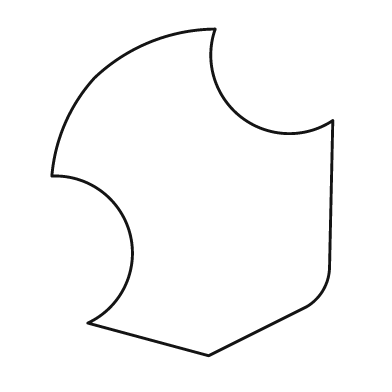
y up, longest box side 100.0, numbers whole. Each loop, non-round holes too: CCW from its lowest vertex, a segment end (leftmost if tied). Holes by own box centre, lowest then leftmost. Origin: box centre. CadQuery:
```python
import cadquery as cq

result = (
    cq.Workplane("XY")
    .moveTo(5.0, -50.0)
    .lineTo(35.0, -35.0)
    .threePointArc((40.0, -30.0), (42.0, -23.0))
    .lineTo(43.0, 22.0)
    .threePointArc((15.0, 23.0), (7.0, 50.0))
    .threePointArc((-13.0, 46.0), (-30.0, 35.0))
    .threePointArc((-39.0, 21.0), (-43.0, 5.0))
    .threePointArc((-19.0, -13.0), (-32.0, -40.0))
    .close()
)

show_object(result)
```